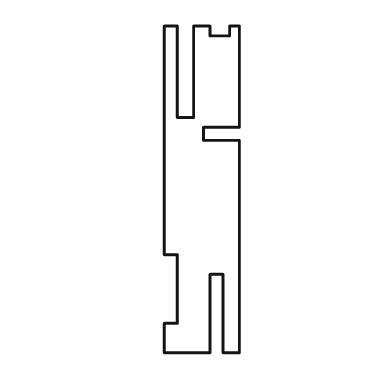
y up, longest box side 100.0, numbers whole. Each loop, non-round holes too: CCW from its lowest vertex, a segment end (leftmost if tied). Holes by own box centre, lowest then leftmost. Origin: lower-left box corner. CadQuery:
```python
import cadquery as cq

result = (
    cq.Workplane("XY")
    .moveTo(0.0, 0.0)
    .lineTo(14.0, 0.0)
    .lineTo(14.0, 24.0)
    .lineTo(18.0, 24.0)
    .lineTo(18.0, 0.0)
    .lineTo(23.0, 0.0)
    .lineTo(23.0, 65.0)
    .lineTo(12.0, 65.0)
    .lineTo(12.0, 69.0)
    .lineTo(23.0, 69.0)
    .lineTo(23.0, 100.0)
    .lineTo(20.0, 100.0)
    .lineTo(20.0, 97.0)
    .lineTo(14.0, 97.0)
    .lineTo(14.0, 100.0)
    .lineTo(9.0, 100.0)
    .lineTo(9.0, 72.0)
    .lineTo(4.0, 72.0)
    .lineTo(4.0, 100.0)
    .lineTo(0.0, 100.0)
    .lineTo(0.0, 30.0)
    .lineTo(4.0, 30.0)
    .lineTo(4.0, 9.0)
    .lineTo(0.0, 9.0)
    .close()
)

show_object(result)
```